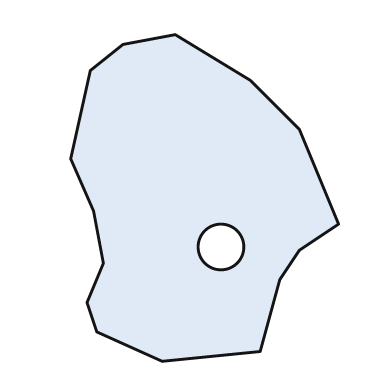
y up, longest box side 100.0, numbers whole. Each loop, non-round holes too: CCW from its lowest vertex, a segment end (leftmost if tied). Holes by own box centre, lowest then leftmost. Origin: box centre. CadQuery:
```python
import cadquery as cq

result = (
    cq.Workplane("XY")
    .moveTo(-13.0, -50.0)
    .lineTo(17.0, -47.0)
    .lineTo(23.0, -25.0)
    .lineTo(29.0, -16.0)
    .lineTo(41.0, -8.0)
    .lineTo(29.0, 21.0)
    .lineTo(14.0, 36.0)
    .lineTo(-9.0, 50.0)
    .lineTo(-25.0, 47.0)
    .lineTo(-35.0, 39.0)
    .lineTo(-41.0, 12.0)
    .lineTo(-34.0, -4.0)
    .lineTo(-31.0, -20.0)
    .lineTo(-36.0, -32.0)
    .lineTo(-33.0, -41.0)
    .close()
    .moveTo(5.0, -15.0)
    .circle(7.0)
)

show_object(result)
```